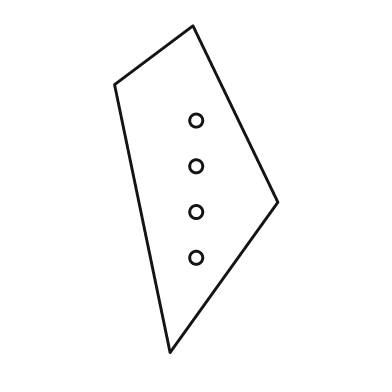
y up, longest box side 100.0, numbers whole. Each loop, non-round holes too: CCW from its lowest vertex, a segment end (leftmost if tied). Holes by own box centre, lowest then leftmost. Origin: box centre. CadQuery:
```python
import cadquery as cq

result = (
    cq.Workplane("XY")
    .moveTo(-8.0, -50.0)
    .lineTo(25.0, -4.0)
    .lineTo(-1.0, 50.0)
    .lineTo(-25.0, 32.0)
    .close()
    .moveTo(0.0, -21.0)
    .circle(2.0)
    .moveTo(0.0, -7.0)
    .circle(2.0)
    .moveTo(0.0, 7.0)
    .circle(2.0)
    .moveTo(0.0, 21.0)
    .circle(2.0)
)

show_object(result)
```